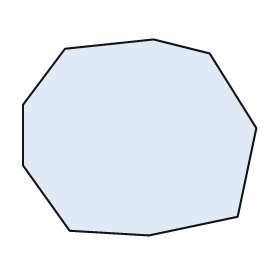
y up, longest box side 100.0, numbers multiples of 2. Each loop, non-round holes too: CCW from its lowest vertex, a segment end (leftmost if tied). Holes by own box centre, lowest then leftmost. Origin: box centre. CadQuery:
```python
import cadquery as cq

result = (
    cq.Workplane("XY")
    .moveTo(4.0, -42.0)
    .lineTo(42.0, -34.0)
    .lineTo(50.0, 4.0)
    .lineTo(30.0, 36.0)
    .lineTo(6.0, 42.0)
    .lineTo(-32.0, 38.0)
    .lineTo(-50.0, 14.0)
    .lineTo(-50.0, -12.0)
    .lineTo(-30.0, -40.0)
    .close()
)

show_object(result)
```